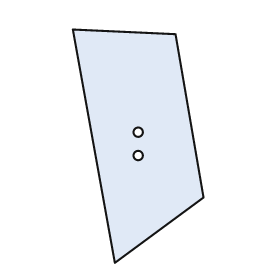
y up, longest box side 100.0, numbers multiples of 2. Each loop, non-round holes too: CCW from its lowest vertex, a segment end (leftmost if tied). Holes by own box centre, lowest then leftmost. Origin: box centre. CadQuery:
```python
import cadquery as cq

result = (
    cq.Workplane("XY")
    .moveTo(-10.0, -50.0)
    .lineTo(28.0, -22.0)
    .lineTo(16.0, 48.0)
    .lineTo(-28.0, 50.0)
    .close()
    .moveTo(0.0, -4.0)
    .circle(2.0)
    .moveTo(0.0, 6.0)
    .circle(2.0)
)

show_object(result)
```